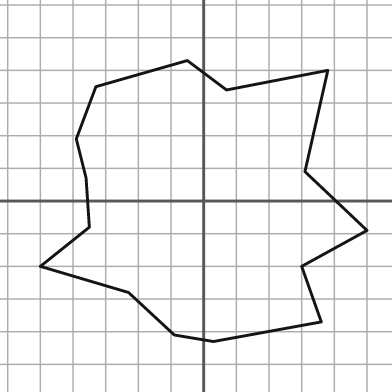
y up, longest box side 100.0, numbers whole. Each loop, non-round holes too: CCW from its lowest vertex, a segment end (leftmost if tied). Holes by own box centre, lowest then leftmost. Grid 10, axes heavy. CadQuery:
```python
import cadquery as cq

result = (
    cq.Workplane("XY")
    .moveTo(3.0, -43.0)
    .lineTo(36.0, -37.0)
    .lineTo(30.0, -20.0)
    .lineTo(50.0, -9.0)
    .lineTo(31.0, 9.0)
    .lineTo(38.0, 40.0)
    .lineTo(7.0, 34.0)
    .lineTo(-5.0, 43.0)
    .lineTo(-33.0, 35.0)
    .lineTo(-39.0, 19.0)
    .lineTo(-36.0, 7.0)
    .lineTo(-35.0, -8.0)
    .lineTo(-50.0, -20.0)
    .lineTo(-23.0, -28.0)
    .lineTo(-9.0, -41.0)
    .close()
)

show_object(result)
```